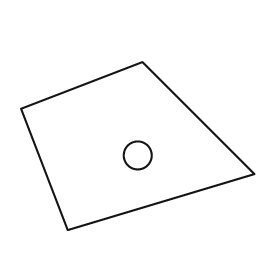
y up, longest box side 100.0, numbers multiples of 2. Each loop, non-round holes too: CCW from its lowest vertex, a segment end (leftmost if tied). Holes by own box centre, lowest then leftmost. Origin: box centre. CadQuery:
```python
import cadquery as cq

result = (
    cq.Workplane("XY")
    .moveTo(-30.0, -36.0)
    .lineTo(50.0, -12.0)
    .lineTo(2.0, 36.0)
    .lineTo(-50.0, 16.0)
    .close()
    .moveTo(0.0, -4.0)
    .circle(6.0)
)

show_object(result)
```